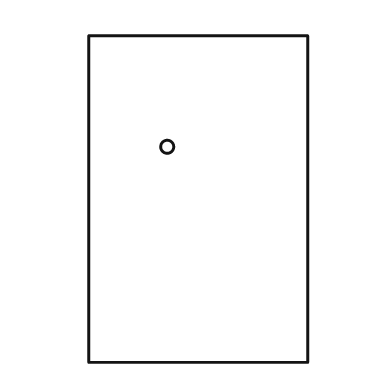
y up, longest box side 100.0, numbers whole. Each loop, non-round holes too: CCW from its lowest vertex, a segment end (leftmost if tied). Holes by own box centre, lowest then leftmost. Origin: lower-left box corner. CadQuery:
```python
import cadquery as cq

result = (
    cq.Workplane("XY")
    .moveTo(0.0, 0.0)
    .lineTo(67.0, 0.0)
    .lineTo(67.0, 100.0)
    .lineTo(0.0, 100.0)
    .close()
    .moveTo(24.0, 66.0)
    .circle(2.0)
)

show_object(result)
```